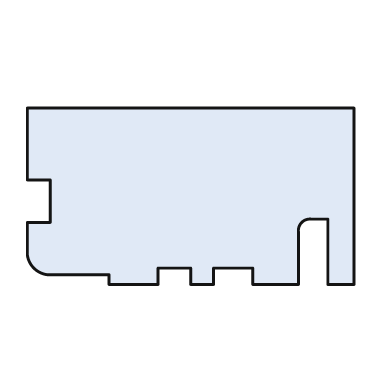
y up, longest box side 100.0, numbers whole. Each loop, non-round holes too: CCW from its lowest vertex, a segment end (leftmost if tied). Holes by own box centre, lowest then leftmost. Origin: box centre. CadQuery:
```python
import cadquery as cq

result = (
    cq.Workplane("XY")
    .moveTo(-25.0, -27.0)
    .lineTo(-10.0, -27.0)
    .lineTo(-10.0, -22.0)
    .lineTo(0.0, -22.0)
    .lineTo(0.0, -27.0)
    .lineTo(7.0, -27.0)
    .lineTo(7.0, -22.0)
    .lineTo(19.0, -22.0)
    .lineTo(19.0, -27.0)
    .lineTo(33.0, -27.0)
    .lineTo(33.0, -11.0)
    .threePointArc((34.0, -8.0), (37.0, -7.0))
    .lineTo(42.0, -7.0)
    .lineTo(42.0, -27.0)
    .lineTo(50.0, -27.0)
    .lineTo(50.0, 27.0)
    .lineTo(-50.0, 27.0)
    .lineTo(-50.0, 5.0)
    .lineTo(-43.0, 5.0)
    .lineTo(-43.0, -8.0)
    .lineTo(-50.0, -8.0)
    .lineTo(-50.0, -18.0)
    .threePointArc((-48.0, -22.0), (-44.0, -24.0))
    .lineTo(-25.0, -24.0)
    .close()
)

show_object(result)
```